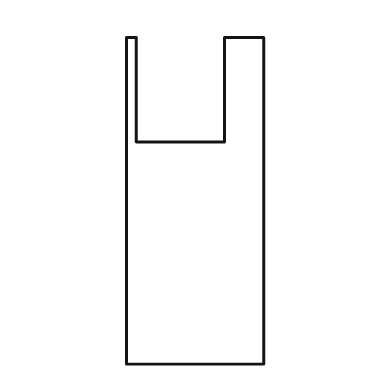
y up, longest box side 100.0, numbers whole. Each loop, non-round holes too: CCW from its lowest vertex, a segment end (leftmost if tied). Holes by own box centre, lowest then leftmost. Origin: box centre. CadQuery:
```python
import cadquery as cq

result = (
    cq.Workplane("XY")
    .moveTo(-21.0, -50.0)
    .lineTo(21.0, -50.0)
    .lineTo(21.0, 50.0)
    .lineTo(9.0, 50.0)
    .lineTo(9.0, 18.0)
    .lineTo(-18.0, 18.0)
    .lineTo(-18.0, 50.0)
    .lineTo(-21.0, 50.0)
    .close()
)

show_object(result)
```